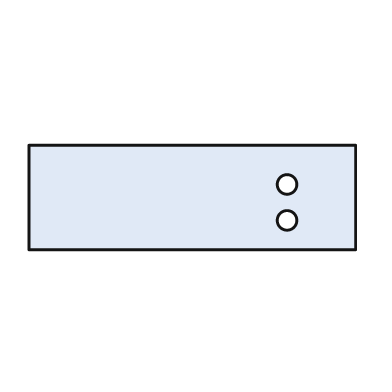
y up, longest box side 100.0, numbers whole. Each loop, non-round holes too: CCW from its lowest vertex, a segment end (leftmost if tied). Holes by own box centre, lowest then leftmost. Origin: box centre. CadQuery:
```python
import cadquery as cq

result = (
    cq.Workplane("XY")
    .moveTo(-50.0, -16.0)
    .lineTo(50.0, -16.0)
    .lineTo(50.0, 16.0)
    .lineTo(-50.0, 16.0)
    .close()
    .moveTo(29.0, -7.0)
    .circle(3.0)
    .moveTo(29.0, 4.0)
    .circle(3.0)
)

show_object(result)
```